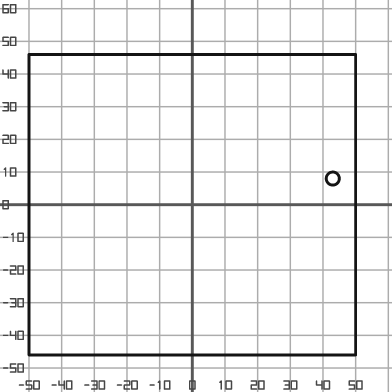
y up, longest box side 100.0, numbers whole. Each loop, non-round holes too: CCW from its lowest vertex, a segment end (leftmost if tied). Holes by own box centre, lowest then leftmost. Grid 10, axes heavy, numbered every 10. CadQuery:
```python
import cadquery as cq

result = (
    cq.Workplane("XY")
    .moveTo(-50.0, -46.0)
    .lineTo(50.0, -46.0)
    .lineTo(50.0, 46.0)
    .lineTo(-50.0, 46.0)
    .close()
    .moveTo(43.0, 8.0)
    .circle(2.0)
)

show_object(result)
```